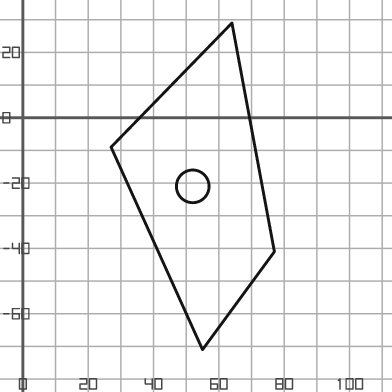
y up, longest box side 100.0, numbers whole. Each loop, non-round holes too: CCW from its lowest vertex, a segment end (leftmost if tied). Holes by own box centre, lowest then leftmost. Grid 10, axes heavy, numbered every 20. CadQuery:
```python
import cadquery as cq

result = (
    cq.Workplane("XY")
    .moveTo(55.0, -71.0)
    .lineTo(77.0, -41.0)
    .lineTo(64.0, 29.0)
    .lineTo(27.0, -9.0)
    .close()
    .moveTo(52.0, -21.0)
    .circle(5.0)
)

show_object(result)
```